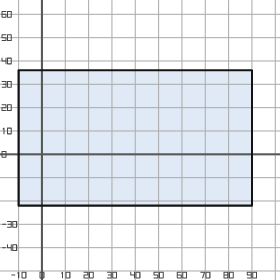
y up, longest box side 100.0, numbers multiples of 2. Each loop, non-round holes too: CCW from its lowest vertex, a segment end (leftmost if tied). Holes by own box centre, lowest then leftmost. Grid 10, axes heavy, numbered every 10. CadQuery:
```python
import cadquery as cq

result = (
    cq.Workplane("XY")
    .moveTo(-10.0, -22.0)
    .lineTo(90.0, -22.0)
    .lineTo(90.0, 36.0)
    .lineTo(-10.0, 36.0)
    .close()
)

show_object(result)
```